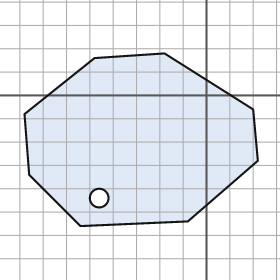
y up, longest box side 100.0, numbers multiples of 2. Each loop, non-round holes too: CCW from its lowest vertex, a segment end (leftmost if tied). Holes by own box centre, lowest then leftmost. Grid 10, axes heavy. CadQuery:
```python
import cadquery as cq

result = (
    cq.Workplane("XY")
    .moveTo(-54.0, -56.0)
    .lineTo(-8.0, -54.0)
    .lineTo(22.0, -28.0)
    .lineTo(20.0, -6.0)
    .lineTo(-18.0, 18.0)
    .lineTo(-48.0, 16.0)
    .lineTo(-78.0, -8.0)
    .lineTo(-76.0, -34.0)
    .close()
    .moveTo(-46.0, -44.0)
    .circle(4.0)
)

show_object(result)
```